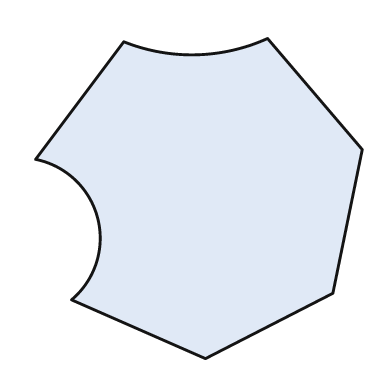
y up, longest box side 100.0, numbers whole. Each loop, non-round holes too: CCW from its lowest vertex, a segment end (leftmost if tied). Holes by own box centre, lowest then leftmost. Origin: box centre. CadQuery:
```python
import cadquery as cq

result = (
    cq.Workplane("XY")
    .moveTo(2.0, -49.0)
    .lineTo(41.0, -29.0)
    .lineTo(50.0, 15.0)
    .lineTo(21.0, 49.0)
    .threePointArc((-1.0, 44.0), (-23.0, 48.0))
    .lineTo(-50.0, 12.0)
    .threePointArc((-31.0, -6.0), (-39.0, -31.0))
    .close()
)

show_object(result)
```